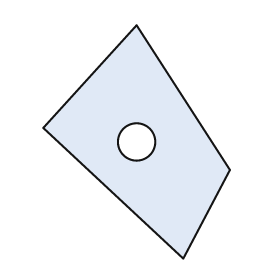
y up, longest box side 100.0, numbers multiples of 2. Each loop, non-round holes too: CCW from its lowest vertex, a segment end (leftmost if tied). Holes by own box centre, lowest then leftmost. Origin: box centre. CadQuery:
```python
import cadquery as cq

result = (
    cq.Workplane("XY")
    .moveTo(20.0, -50.0)
    .lineTo(40.0, -12.0)
    .lineTo(0.0, 50.0)
    .lineTo(-40.0, 6.0)
    .close()
    .moveTo(0.0, 0.0)
    .circle(8.0)
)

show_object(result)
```